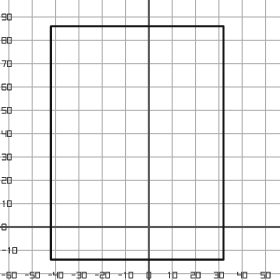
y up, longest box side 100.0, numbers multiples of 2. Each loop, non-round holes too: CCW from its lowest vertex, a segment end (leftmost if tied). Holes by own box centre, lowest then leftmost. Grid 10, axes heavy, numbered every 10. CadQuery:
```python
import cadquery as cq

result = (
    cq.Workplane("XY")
    .moveTo(-42.0, -14.0)
    .lineTo(32.0, -14.0)
    .lineTo(32.0, 86.0)
    .lineTo(-42.0, 86.0)
    .close()
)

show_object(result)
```